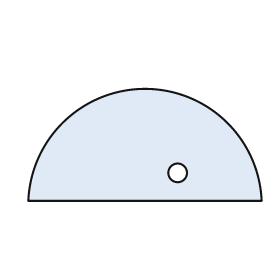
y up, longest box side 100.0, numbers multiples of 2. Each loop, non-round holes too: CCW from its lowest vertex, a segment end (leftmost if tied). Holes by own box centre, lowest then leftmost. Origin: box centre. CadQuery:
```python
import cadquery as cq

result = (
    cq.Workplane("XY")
    .moveTo(-50.0, -24.0)
    .lineTo(50.0, -24.0)
    .threePointArc((0.0, 24.0), (-50.0, -24.0))
    .close()
    .moveTo(14.0, -12.0)
    .circle(4.0)
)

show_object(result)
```